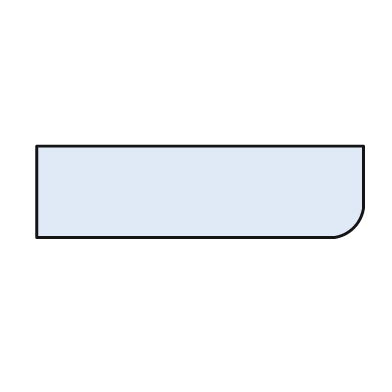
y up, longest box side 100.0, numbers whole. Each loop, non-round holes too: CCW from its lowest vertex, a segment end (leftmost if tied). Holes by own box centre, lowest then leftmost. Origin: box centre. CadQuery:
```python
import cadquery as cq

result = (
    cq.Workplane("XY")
    .moveTo(-50.0, -14.0)
    .lineTo(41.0, -14.0)
    .threePointArc((47.0, -11.0), (50.0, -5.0))
    .lineTo(50.0, 14.0)
    .lineTo(-50.0, 14.0)
    .close()
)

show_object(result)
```